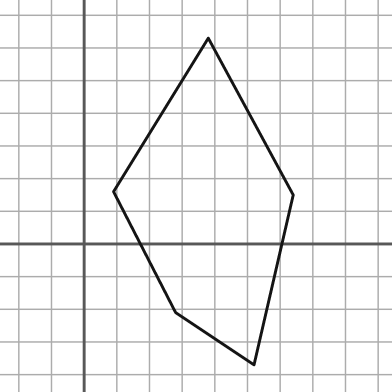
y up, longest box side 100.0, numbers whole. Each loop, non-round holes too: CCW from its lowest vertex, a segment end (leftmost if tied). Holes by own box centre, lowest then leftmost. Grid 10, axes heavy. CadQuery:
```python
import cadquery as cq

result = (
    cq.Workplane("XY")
    .moveTo(52.0, -37.0)
    .lineTo(64.0, 15.0)
    .lineTo(38.0, 63.0)
    .lineTo(9.0, 16.0)
    .lineTo(28.0, -21.0)
    .close()
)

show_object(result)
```